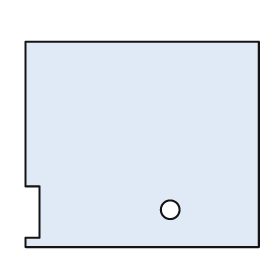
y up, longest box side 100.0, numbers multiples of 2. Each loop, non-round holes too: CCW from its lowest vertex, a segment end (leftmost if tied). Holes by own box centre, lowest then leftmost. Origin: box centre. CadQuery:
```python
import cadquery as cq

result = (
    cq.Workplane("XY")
    .moveTo(-50.0, -44.0)
    .lineTo(50.0, -44.0)
    .lineTo(50.0, 44.0)
    .lineTo(-50.0, 44.0)
    .lineTo(-50.0, -18.0)
    .lineTo(-44.0, -18.0)
    .lineTo(-44.0, -40.0)
    .lineTo(-50.0, -40.0)
    .close()
    .moveTo(12.0, -28.0)
    .circle(4.0)
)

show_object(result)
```